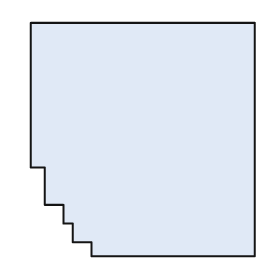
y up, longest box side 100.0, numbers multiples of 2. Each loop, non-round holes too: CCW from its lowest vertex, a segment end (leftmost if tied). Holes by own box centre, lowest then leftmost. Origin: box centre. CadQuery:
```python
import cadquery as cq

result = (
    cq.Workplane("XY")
    .moveTo(-22.0, -50.0)
    .lineTo(48.0, -50.0)
    .lineTo(48.0, 50.0)
    .lineTo(-48.0, 50.0)
    .lineTo(-48.0, -12.0)
    .lineTo(-42.0, -12.0)
    .lineTo(-42.0, -28.0)
    .lineTo(-34.0, -28.0)
    .lineTo(-34.0, -36.0)
    .lineTo(-30.0, -36.0)
    .lineTo(-30.0, -44.0)
    .lineTo(-22.0, -44.0)
    .close()
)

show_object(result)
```